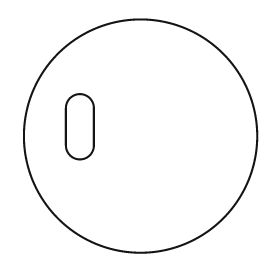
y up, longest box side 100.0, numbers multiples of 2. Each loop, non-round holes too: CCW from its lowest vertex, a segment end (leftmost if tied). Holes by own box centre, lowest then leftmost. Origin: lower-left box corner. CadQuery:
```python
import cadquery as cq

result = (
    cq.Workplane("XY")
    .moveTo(50.0, 50.0)
    .circle(50.0)
    .moveTo(18.0, 46.0)
    .threePointArc((24.0, 40.0), (30.0, 46.0))
    .lineTo(30.0, 62.0)
    .threePointArc((24.0, 68.0), (18.0, 62.0))
    .close()
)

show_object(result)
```